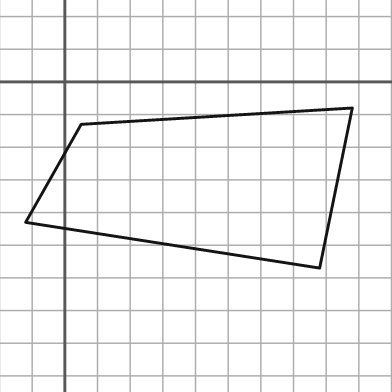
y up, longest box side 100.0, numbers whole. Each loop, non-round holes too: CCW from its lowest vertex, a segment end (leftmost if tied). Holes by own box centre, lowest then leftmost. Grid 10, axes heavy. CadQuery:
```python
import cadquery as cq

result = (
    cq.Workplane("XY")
    .moveTo(78.0, -57.0)
    .lineTo(88.0, -8.0)
    .lineTo(5.0, -13.0)
    .lineTo(-12.0, -43.0)
    .close()
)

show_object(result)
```